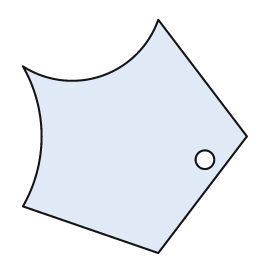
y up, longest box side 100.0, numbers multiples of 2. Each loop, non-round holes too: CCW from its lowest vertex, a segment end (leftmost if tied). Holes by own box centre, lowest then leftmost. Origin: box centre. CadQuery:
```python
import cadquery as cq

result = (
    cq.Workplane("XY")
    .moveTo(10.0, -50.0)
    .lineTo(48.0, 0.0)
    .lineTo(10.0, 50.0)
    .threePointArc((-14.0, 26.0), (-48.0, 30.0))
    .threePointArc((-40.0, 0.0), (-48.0, -30.0))
    .close()
    .moveTo(30.0, -10.0)
    .circle(4.0)
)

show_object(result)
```